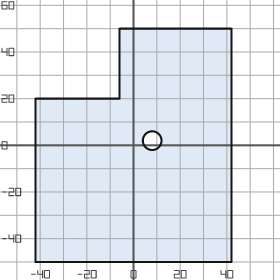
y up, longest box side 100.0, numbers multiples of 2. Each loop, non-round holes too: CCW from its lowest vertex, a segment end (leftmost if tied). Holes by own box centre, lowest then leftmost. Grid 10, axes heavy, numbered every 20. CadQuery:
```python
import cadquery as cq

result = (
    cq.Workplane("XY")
    .moveTo(-42.0, -50.0)
    .lineTo(42.0, -50.0)
    .lineTo(42.0, 50.0)
    .lineTo(-6.0, 50.0)
    .lineTo(-6.0, 20.0)
    .lineTo(-42.0, 20.0)
    .close()
    .moveTo(8.0, 2.0)
    .circle(4.0)
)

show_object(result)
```